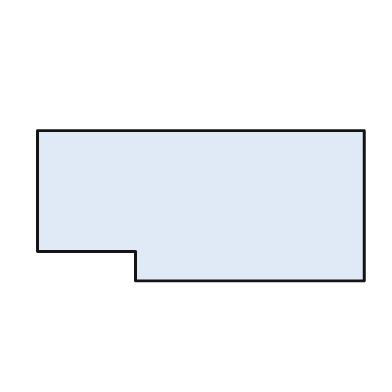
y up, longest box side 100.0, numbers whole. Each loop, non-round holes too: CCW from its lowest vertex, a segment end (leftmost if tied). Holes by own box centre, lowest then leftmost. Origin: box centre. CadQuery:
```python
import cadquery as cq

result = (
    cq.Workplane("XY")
    .moveTo(-20.0, -23.0)
    .lineTo(50.0, -23.0)
    .lineTo(50.0, 23.0)
    .lineTo(-50.0, 23.0)
    .lineTo(-50.0, -14.0)
    .lineTo(-20.0, -14.0)
    .close()
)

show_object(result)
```